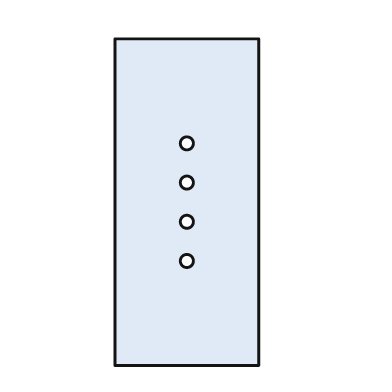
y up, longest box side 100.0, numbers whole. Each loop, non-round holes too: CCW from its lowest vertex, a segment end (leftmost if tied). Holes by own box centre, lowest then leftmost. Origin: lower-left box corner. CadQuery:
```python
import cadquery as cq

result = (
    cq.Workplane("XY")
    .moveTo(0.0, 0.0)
    .lineTo(44.0, 0.0)
    .lineTo(44.0, 100.0)
    .lineTo(0.0, 100.0)
    .close()
    .moveTo(22.0, 32.0)
    .circle(2.0)
    .moveTo(22.0, 44.0)
    .circle(2.0)
    .moveTo(22.0, 56.0)
    .circle(2.0)
    .moveTo(22.0, 68.0)
    .circle(2.0)
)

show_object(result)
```